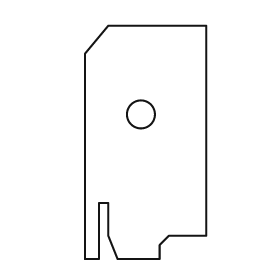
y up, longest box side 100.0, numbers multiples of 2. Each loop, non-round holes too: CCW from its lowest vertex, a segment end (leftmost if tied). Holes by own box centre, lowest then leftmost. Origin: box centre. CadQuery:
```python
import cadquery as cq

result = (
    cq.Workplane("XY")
    .moveTo(-26.0, -50.0)
    .lineTo(-20.0, -50.0)
    .lineTo(-20.0, -26.0)
    .lineTo(-16.0, -26.0)
    .lineTo(-16.0, -40.0)
    .lineTo(-12.0, -50.0)
    .lineTo(6.0, -50.0)
    .lineTo(6.0, -44.0)
    .lineTo(10.0, -40.0)
    .lineTo(26.0, -40.0)
    .lineTo(26.0, 50.0)
    .lineTo(-16.0, 50.0)
    .lineTo(-26.0, 38.0)
    .close()
    .moveTo(-2.0, 12.0)
    .circle(6.0)
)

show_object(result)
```